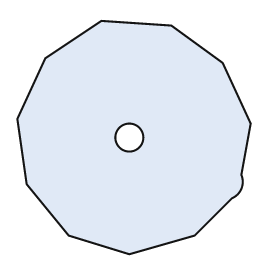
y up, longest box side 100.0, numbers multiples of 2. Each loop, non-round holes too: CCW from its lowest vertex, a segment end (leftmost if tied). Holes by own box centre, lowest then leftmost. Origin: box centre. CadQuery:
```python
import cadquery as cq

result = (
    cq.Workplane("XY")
    .moveTo(-2.0, -50.0)
    .lineTo(26.0, -42.0)
    .lineTo(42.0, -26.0)
    .threePointArc((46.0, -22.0), (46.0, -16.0))
    .lineTo(50.0, 6.0)
    .lineTo(38.0, 32.0)
    .lineTo(16.0, 48.0)
    .lineTo(-14.0, 50.0)
    .lineTo(-38.0, 34.0)
    .lineTo(-50.0, 8.0)
    .lineTo(-46.0, -20.0)
    .lineTo(-28.0, -42.0)
    .close()
    .moveTo(-2.0, 0.0)
    .circle(6.0)
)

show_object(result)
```